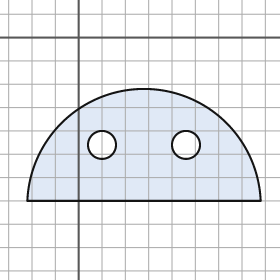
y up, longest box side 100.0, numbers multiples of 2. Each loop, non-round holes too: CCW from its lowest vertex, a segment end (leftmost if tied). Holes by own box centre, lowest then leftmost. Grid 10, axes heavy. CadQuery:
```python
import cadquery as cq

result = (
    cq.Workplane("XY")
    .moveTo(-22.0, -70.0)
    .lineTo(78.0, -70.0)
    .threePointArc((28.0, -22.0), (-22.0, -70.0))
    .close()
    .moveTo(10.0, -46.0)
    .circle(6.0)
    .moveTo(46.0, -46.0)
    .circle(6.0)
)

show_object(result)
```